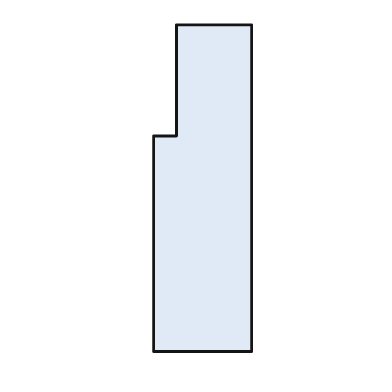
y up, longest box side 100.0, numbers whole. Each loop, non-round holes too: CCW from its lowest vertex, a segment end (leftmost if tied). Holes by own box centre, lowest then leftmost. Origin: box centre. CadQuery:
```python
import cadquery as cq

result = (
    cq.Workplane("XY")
    .moveTo(-15.0, -50.0)
    .lineTo(15.0, -50.0)
    .lineTo(15.0, 50.0)
    .lineTo(-8.0, 50.0)
    .lineTo(-8.0, 16.0)
    .lineTo(-15.0, 16.0)
    .close()
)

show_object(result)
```